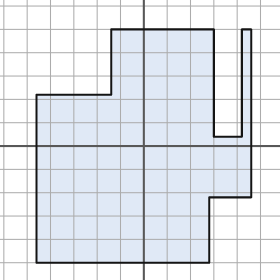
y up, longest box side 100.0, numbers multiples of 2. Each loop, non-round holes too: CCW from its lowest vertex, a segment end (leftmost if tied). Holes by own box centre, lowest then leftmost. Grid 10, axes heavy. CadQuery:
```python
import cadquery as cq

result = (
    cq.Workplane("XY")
    .moveTo(-46.0, -50.0)
    .lineTo(28.0, -50.0)
    .lineTo(28.0, -22.0)
    .lineTo(46.0, -22.0)
    .lineTo(46.0, 50.0)
    .lineTo(42.0, 50.0)
    .lineTo(42.0, 4.0)
    .lineTo(30.0, 4.0)
    .lineTo(30.0, 50.0)
    .lineTo(-14.0, 50.0)
    .lineTo(-14.0, 22.0)
    .lineTo(-46.0, 22.0)
    .close()
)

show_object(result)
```